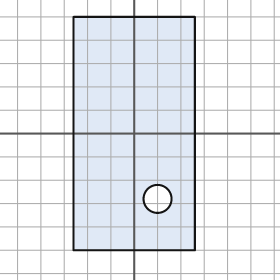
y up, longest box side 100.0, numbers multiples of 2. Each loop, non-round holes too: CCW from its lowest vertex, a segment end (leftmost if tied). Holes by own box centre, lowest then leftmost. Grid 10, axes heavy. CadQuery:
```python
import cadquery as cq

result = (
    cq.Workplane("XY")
    .moveTo(-26.0, -50.0)
    .lineTo(26.0, -50.0)
    .lineTo(26.0, 50.0)
    .lineTo(-26.0, 50.0)
    .close()
    .moveTo(10.0, -28.0)
    .circle(6.0)
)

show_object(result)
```